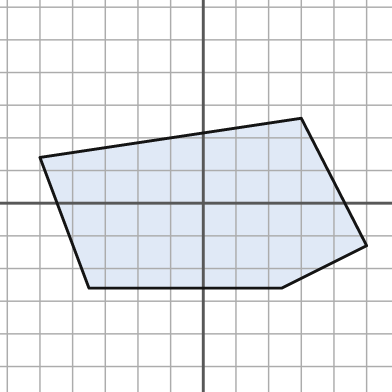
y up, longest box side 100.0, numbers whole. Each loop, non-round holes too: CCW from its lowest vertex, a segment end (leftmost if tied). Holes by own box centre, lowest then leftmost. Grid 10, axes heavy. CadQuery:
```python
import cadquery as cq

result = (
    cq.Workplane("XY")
    .moveTo(-35.0, -26.0)
    .lineTo(24.0, -26.0)
    .lineTo(50.0, -13.0)
    .lineTo(30.0, 26.0)
    .lineTo(-50.0, 14.0)
    .close()
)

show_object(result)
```